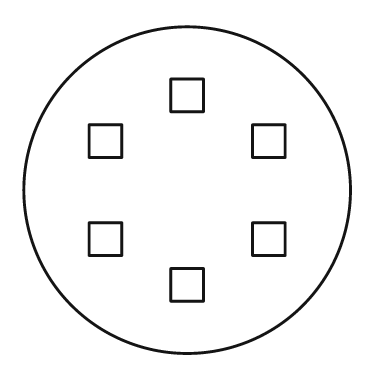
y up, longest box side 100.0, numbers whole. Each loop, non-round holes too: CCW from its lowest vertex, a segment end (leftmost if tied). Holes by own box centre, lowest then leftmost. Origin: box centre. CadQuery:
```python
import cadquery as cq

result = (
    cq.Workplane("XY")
    .moveTo(0.0, 0.0)
    .circle(50.0)
    .moveTo(-5.0, -34.0)
    .lineTo(5.0, -34.0)
    .lineTo(5.0, -24.0)
    .lineTo(-5.0, -24.0)
    .close()
    .moveTo(-30.0, -20.0)
    .lineTo(-20.0, -20.0)
    .lineTo(-20.0, -10.0)
    .lineTo(-30.0, -10.0)
    .close()
    .moveTo(20.0, -20.0)
    .lineTo(30.0, -20.0)
    .lineTo(30.0, -10.0)
    .lineTo(20.0, -10.0)
    .close()
    .moveTo(-30.0, 10.0)
    .lineTo(-20.0, 10.0)
    .lineTo(-20.0, 20.0)
    .lineTo(-30.0, 20.0)
    .close()
    .moveTo(20.0, 10.0)
    .lineTo(30.0, 10.0)
    .lineTo(30.0, 20.0)
    .lineTo(20.0, 20.0)
    .close()
    .moveTo(-5.0, 24.0)
    .lineTo(5.0, 24.0)
    .lineTo(5.0, 34.0)
    .lineTo(-5.0, 34.0)
    .close()
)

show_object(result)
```